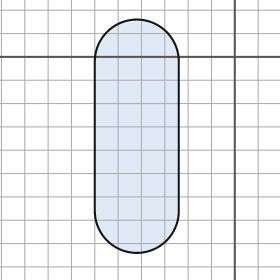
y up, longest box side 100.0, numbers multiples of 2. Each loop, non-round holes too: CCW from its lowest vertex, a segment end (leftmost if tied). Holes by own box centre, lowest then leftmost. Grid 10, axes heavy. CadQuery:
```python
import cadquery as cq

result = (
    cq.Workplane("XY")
    .moveTo(-60.0, -66.0)
    .threePointArc((-42.0, -84.0), (-24.0, -66.0))
    .lineTo(-24.0, -2.0)
    .threePointArc((-42.0, 16.0), (-60.0, -2.0))
    .close()
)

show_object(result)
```